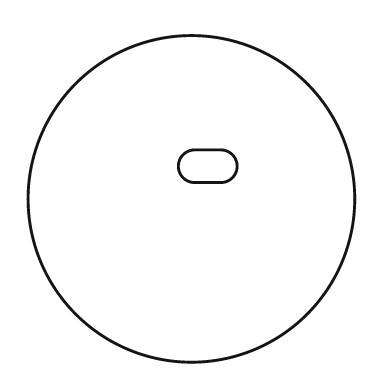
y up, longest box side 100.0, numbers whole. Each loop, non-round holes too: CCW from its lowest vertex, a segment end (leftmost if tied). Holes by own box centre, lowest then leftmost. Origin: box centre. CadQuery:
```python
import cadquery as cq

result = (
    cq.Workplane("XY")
    .moveTo(0.0, 0.0)
    .circle(50.0)
    .moveTo(1.0, 5.0)
    .lineTo(9.0, 5.0)
    .threePointArc((14.0, 10.0), (9.0, 15.0))
    .lineTo(1.0, 15.0)
    .threePointArc((-4.0, 10.0), (1.0, 5.0))
    .close()
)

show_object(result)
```